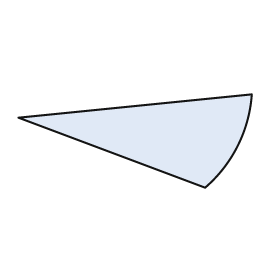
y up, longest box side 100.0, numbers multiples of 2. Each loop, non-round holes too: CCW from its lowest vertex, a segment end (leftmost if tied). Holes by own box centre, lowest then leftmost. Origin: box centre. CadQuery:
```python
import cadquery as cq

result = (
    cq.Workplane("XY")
    .moveTo(30.0, -20.0)
    .threePointArc((44.0, -2.0), (50.0, 20.0))
    .lineTo(-50.0, 10.0)
    .close()
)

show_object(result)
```